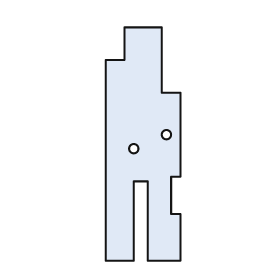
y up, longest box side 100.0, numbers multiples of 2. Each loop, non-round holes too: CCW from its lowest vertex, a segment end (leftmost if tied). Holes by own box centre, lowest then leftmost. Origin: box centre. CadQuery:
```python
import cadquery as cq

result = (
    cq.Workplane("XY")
    .moveTo(-16.0, -50.0)
    .lineTo(-4.0, -50.0)
    .lineTo(-4.0, -16.0)
    .lineTo(2.0, -16.0)
    .lineTo(2.0, -50.0)
    .lineTo(16.0, -50.0)
    .lineTo(16.0, -30.0)
    .lineTo(12.0, -30.0)
    .lineTo(12.0, -14.0)
    .lineTo(16.0, -14.0)
    .lineTo(16.0, 22.0)
    .lineTo(8.0, 22.0)
    .lineTo(8.0, 50.0)
    .lineTo(-8.0, 50.0)
    .lineTo(-8.0, 36.0)
    .lineTo(-16.0, 36.0)
    .close()
    .moveTo(-4.0, -2.0)
    .circle(2.0)
    .moveTo(10.0, 4.0)
    .circle(2.0)
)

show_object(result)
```